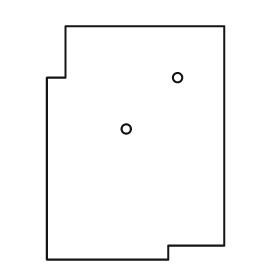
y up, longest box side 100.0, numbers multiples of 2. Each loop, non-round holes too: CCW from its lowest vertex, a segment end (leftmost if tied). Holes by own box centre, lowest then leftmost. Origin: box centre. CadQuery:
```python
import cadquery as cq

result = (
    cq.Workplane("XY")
    .moveTo(-38.0, -50.0)
    .lineTo(14.0, -50.0)
    .lineTo(14.0, -44.0)
    .lineTo(38.0, -44.0)
    .lineTo(38.0, 50.0)
    .lineTo(-30.0, 50.0)
    .lineTo(-30.0, 28.0)
    .lineTo(-38.0, 28.0)
    .close()
    .moveTo(-4.0, 6.0)
    .circle(2.0)
    .moveTo(18.0, 28.0)
    .circle(2.0)
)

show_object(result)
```